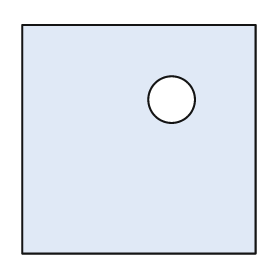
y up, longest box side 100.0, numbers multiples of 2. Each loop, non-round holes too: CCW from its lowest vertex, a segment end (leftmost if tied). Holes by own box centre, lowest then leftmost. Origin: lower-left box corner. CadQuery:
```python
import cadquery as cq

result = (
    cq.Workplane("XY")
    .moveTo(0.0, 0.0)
    .lineTo(100.0, 0.0)
    .lineTo(100.0, 98.0)
    .lineTo(0.0, 98.0)
    .close()
    .moveTo(64.0, 66.0)
    .circle(10.0)
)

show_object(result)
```